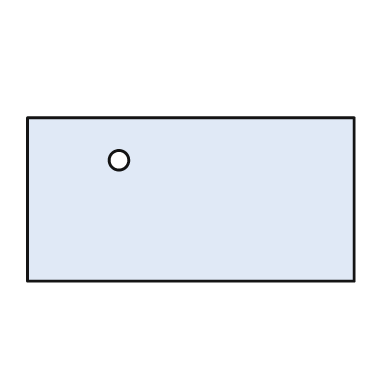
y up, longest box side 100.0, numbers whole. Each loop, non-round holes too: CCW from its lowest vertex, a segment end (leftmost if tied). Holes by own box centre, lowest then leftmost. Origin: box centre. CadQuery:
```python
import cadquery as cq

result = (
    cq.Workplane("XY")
    .moveTo(-50.0, -25.0)
    .lineTo(50.0, -25.0)
    .lineTo(50.0, 25.0)
    .lineTo(-50.0, 25.0)
    .close()
    .moveTo(-22.0, 12.0)
    .circle(3.0)
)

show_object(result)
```